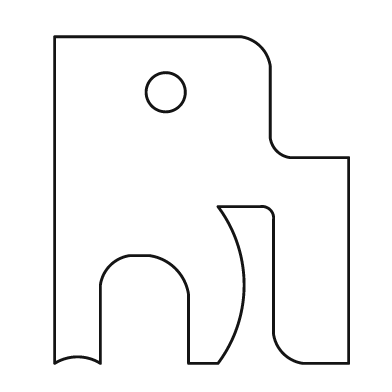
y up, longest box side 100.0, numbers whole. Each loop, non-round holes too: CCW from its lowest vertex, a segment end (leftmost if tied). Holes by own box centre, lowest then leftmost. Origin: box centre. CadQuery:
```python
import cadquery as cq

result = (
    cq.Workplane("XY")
    .moveTo(-45.0, -50.0)
    .threePointArc((-38.0, -48.0), (-31.0, -50.0))
    .lineTo(-31.0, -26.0)
    .threePointArc((-28.0, -20.0), (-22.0, -17.0))
    .lineTo(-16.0, -17.0)
    .threePointArc((-8.0, -21.0), (-4.0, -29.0))
    .lineTo(-4.0, -50.0)
    .lineTo(5.0, -50.0)
    .threePointArc((13.0, -26.0), (5.0, -2.0))
    .lineTo(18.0, -2.0)
    .threePointArc((21.0, -3.0), (22.0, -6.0))
    .lineTo(22.0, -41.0)
    .threePointArc((25.0, -47.0), (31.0, -50.0))
    .lineTo(45.0, -50.0)
    .lineTo(45.0, 13.0)
    .lineTo(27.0, 13.0)
    .threePointArc((23.0, 15.0), (21.0, 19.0))
    .lineTo(21.0, 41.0)
    .threePointArc((18.0, 47.0), (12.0, 50.0))
    .lineTo(-45.0, 50.0)
    .close()
    .moveTo(-11.0, 33.0)
    .circle(6.0)
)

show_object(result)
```